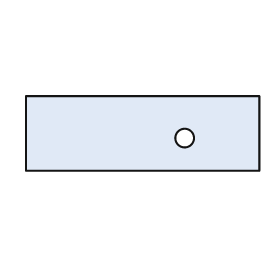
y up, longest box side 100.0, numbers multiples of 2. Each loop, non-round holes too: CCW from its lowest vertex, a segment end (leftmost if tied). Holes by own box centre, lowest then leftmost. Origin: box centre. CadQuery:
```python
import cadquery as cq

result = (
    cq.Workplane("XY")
    .moveTo(-50.0, -16.0)
    .lineTo(50.0, -16.0)
    .lineTo(50.0, 16.0)
    .lineTo(-50.0, 16.0)
    .close()
    .moveTo(18.0, -2.0)
    .circle(4.0)
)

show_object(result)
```